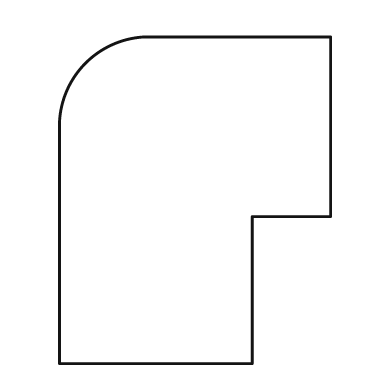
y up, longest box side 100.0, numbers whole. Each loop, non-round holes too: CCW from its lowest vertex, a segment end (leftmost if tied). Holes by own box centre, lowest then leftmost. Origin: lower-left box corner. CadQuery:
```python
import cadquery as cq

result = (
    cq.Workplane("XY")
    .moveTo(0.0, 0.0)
    .lineTo(59.0, 0.0)
    .lineTo(59.0, 45.0)
    .lineTo(83.0, 45.0)
    .lineTo(83.0, 100.0)
    .lineTo(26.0, 100.0)
    .threePointArc((8.0, 92.0), (0.0, 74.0))
    .close()
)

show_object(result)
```